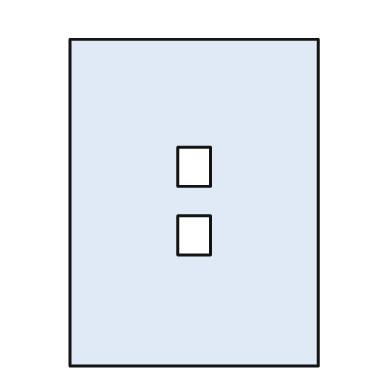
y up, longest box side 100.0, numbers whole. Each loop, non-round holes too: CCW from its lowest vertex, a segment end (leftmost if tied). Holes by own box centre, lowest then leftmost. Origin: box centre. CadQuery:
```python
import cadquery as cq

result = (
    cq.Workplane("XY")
    .moveTo(-38.0, -50.0)
    .lineTo(38.0, -50.0)
    .lineTo(38.0, 50.0)
    .lineTo(-38.0, 50.0)
    .close()
    .moveTo(-5.0, -16.0)
    .lineTo(5.0, -16.0)
    .lineTo(5.0, -4.0)
    .lineTo(-5.0, -4.0)
    .close()
    .moveTo(-5.0, 5.0)
    .lineTo(5.0, 5.0)
    .lineTo(5.0, 17.0)
    .lineTo(-5.0, 17.0)
    .close()
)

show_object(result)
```